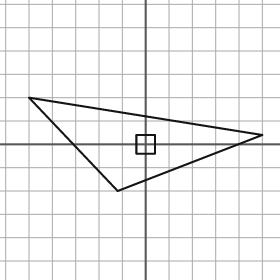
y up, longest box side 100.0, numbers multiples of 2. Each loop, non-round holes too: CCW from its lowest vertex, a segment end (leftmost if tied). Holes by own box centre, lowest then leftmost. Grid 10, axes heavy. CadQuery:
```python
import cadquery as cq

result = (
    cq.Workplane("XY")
    .moveTo(-12.0, -20.0)
    .lineTo(50.0, 4.0)
    .lineTo(-50.0, 20.0)
    .close()
    .moveTo(-4.0, -4.0)
    .lineTo(4.0, -4.0)
    .lineTo(4.0, 4.0)
    .lineTo(-4.0, 4.0)
    .close()
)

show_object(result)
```